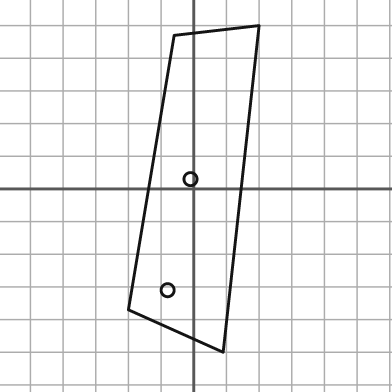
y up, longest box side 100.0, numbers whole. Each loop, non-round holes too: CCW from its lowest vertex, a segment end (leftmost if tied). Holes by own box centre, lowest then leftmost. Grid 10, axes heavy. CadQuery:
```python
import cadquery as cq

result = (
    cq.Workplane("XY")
    .moveTo(9.0, -50.0)
    .lineTo(20.0, 50.0)
    .lineTo(-6.0, 47.0)
    .lineTo(-20.0, -37.0)
    .close()
    .moveTo(-8.0, -31.0)
    .circle(2.0)
    .moveTo(-1.0, 3.0)
    .circle(2.0)
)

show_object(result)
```